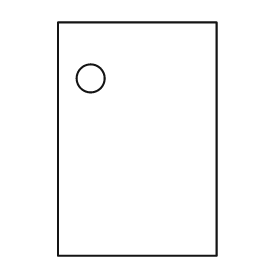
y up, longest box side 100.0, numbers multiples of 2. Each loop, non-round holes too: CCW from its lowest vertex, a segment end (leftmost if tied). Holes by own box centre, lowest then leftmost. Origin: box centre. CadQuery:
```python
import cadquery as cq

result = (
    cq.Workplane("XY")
    .moveTo(-34.0, -50.0)
    .lineTo(34.0, -50.0)
    .lineTo(34.0, 50.0)
    .lineTo(-34.0, 50.0)
    .close()
    .moveTo(-20.0, 26.0)
    .circle(6.0)
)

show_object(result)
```